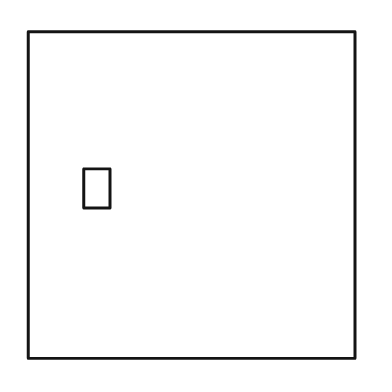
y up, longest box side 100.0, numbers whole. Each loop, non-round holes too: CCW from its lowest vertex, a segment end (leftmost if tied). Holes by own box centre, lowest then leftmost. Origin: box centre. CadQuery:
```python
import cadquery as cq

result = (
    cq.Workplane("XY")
    .moveTo(-50.0, -50.0)
    .lineTo(50.0, -50.0)
    .lineTo(50.0, 50.0)
    .lineTo(-50.0, 50.0)
    .close()
    .moveTo(-33.0, -4.0)
    .lineTo(-25.0, -4.0)
    .lineTo(-25.0, 8.0)
    .lineTo(-33.0, 8.0)
    .close()
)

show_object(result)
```